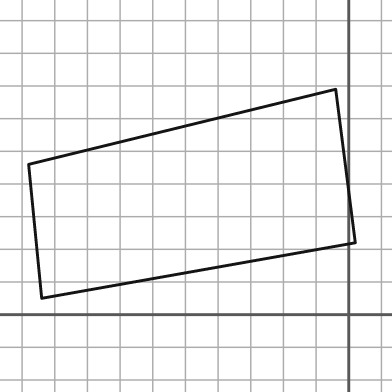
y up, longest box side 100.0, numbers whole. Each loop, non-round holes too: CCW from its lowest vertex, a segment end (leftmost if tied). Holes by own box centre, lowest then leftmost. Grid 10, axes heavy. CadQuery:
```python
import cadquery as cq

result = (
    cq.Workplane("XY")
    .moveTo(-94.0, 5.0)
    .lineTo(2.0, 22.0)
    .lineTo(-4.0, 69.0)
    .lineTo(-98.0, 46.0)
    .close()
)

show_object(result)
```